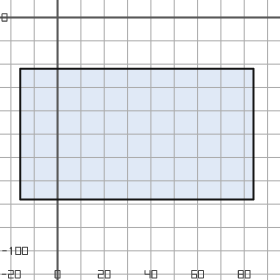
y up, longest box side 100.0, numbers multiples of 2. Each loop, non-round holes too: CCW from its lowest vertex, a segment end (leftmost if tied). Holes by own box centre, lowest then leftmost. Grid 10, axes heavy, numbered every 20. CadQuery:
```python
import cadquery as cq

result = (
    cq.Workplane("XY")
    .moveTo(-16.0, -78.0)
    .lineTo(84.0, -78.0)
    .lineTo(84.0, -22.0)
    .lineTo(-16.0, -22.0)
    .close()
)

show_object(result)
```